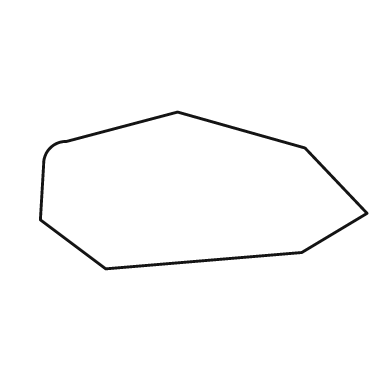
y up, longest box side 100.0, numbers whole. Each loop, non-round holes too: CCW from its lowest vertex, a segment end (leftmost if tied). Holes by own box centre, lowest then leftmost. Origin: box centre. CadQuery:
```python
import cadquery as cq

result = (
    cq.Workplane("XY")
    .moveTo(-30.0, -24.0)
    .lineTo(30.0, -19.0)
    .lineTo(50.0, -7.0)
    .lineTo(31.0, 13.0)
    .lineTo(-8.0, 24.0)
    .lineTo(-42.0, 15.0)
    .threePointArc((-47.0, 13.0), (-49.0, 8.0))
    .lineTo(-50.0, -9.0)
    .close()
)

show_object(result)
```